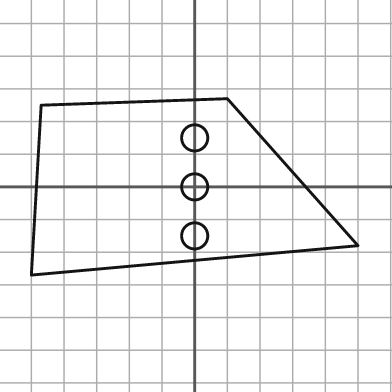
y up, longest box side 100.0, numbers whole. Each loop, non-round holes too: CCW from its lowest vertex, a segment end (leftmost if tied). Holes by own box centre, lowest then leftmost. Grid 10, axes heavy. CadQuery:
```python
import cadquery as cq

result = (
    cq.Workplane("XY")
    .moveTo(-50.0, -27.0)
    .lineTo(50.0, -18.0)
    .lineTo(10.0, 27.0)
    .lineTo(-47.0, 25.0)
    .close()
    .moveTo(0.0, -15.0)
    .circle(4.0)
    .moveTo(0.0, 0.0)
    .circle(4.0)
    .moveTo(0.0, 15.0)
    .circle(4.0)
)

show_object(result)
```